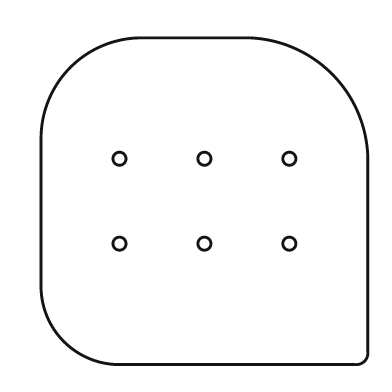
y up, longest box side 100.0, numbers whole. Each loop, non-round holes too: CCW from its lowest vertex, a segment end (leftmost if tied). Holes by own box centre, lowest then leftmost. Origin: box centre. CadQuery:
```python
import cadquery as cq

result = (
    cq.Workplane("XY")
    .moveTo(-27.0, -50.0)
    .lineTo(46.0, -50.0)
    .threePointArc((49.0, -49.0), (50.0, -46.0))
    .lineTo(50.0, 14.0)
    .threePointArc((39.0, 39.0), (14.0, 50.0))
    .lineTo(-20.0, 50.0)
    .threePointArc((-41.0, 41.0), (-50.0, 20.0))
    .lineTo(-50.0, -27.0)
    .threePointArc((-43.0, -43.0), (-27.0, -50.0))
    .close()
    .moveTo(-26.0, -13.0)
    .circle(2.0)
    .moveTo(0.0, -13.0)
    .circle(2.0)
    .moveTo(26.0, -13.0)
    .circle(2.0)
    .moveTo(-26.0, 13.0)
    .circle(2.0)
    .moveTo(0.0, 13.0)
    .circle(2.0)
    .moveTo(26.0, 13.0)
    .circle(2.0)
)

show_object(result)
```